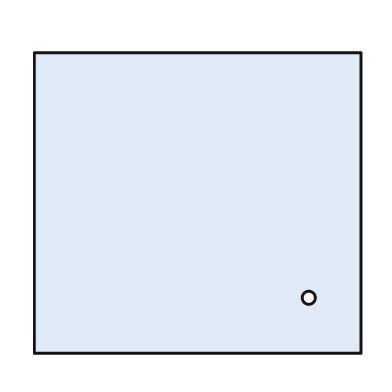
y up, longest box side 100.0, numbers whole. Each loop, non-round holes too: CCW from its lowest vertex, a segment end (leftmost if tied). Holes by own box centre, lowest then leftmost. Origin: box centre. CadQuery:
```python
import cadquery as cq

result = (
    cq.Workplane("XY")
    .moveTo(-50.0, -46.0)
    .lineTo(50.0, -46.0)
    .lineTo(50.0, 46.0)
    .lineTo(-50.0, 46.0)
    .close()
    .moveTo(34.0, -29.0)
    .circle(2.0)
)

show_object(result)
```